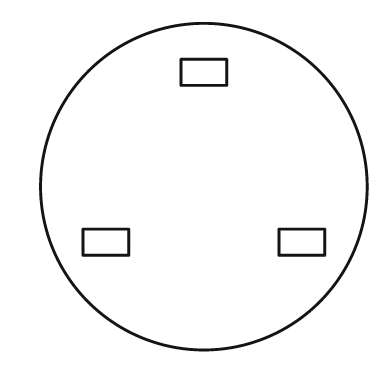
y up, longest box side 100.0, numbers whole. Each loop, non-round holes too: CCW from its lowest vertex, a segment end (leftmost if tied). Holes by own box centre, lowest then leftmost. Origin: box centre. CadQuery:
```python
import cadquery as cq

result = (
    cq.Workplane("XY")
    .moveTo(0.0, 0.0)
    .circle(50.0)
    .moveTo(-37.0, -21.0)
    .lineTo(-23.0, -21.0)
    .lineTo(-23.0, -13.0)
    .lineTo(-37.0, -13.0)
    .close()
    .moveTo(23.0, -21.0)
    .lineTo(37.0, -21.0)
    .lineTo(37.0, -13.0)
    .lineTo(23.0, -13.0)
    .close()
    .moveTo(-7.0, 31.0)
    .lineTo(7.0, 31.0)
    .lineTo(7.0, 39.0)
    .lineTo(-7.0, 39.0)
    .close()
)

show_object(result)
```